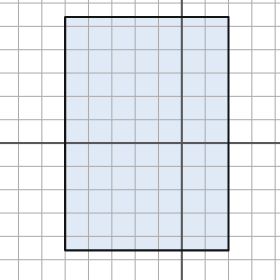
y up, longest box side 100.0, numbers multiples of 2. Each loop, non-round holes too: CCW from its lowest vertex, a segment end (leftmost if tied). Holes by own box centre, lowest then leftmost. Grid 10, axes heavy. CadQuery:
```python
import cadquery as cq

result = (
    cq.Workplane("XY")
    .moveTo(-50.0, -46.0)
    .lineTo(20.0, -46.0)
    .lineTo(20.0, 54.0)
    .lineTo(-50.0, 54.0)
    .close()
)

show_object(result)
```